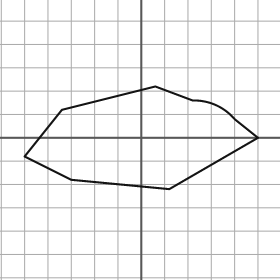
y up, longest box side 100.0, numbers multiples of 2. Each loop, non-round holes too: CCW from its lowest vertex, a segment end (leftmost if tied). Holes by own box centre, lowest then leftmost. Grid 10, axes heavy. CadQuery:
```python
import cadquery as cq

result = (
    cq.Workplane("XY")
    .moveTo(12.0, -22.0)
    .lineTo(50.0, 0.0)
    .lineTo(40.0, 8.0)
    .threePointArc((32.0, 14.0), (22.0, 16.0))
    .lineTo(6.0, 22.0)
    .lineTo(-34.0, 12.0)
    .lineTo(-50.0, -8.0)
    .lineTo(-30.0, -18.0)
    .close()
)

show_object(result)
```